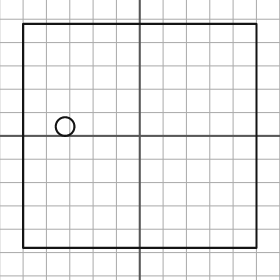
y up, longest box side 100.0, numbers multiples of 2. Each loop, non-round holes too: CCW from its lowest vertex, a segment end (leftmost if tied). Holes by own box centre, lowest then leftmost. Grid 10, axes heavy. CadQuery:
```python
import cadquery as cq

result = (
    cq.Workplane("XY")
    .moveTo(-50.0, -48.0)
    .lineTo(50.0, -48.0)
    .lineTo(50.0, 48.0)
    .lineTo(-50.0, 48.0)
    .close()
    .moveTo(-32.0, 4.0)
    .circle(4.0)
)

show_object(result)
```